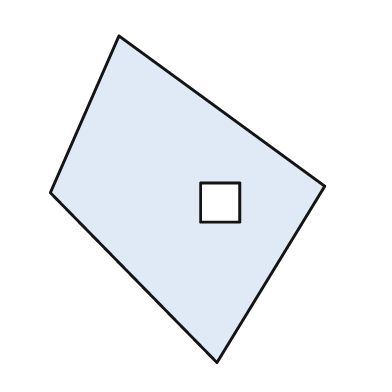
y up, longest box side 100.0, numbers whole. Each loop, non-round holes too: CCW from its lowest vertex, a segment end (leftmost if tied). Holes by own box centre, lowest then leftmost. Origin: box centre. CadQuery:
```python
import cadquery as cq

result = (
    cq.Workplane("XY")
    .moveTo(9.0, -50.0)
    .lineTo(42.0, 4.0)
    .lineTo(-21.0, 50.0)
    .lineTo(-42.0, 2.0)
    .close()
    .moveTo(4.0, -7.0)
    .lineTo(16.0, -7.0)
    .lineTo(16.0, 5.0)
    .lineTo(4.0, 5.0)
    .close()
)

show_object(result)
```